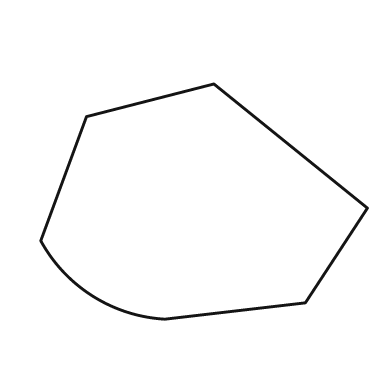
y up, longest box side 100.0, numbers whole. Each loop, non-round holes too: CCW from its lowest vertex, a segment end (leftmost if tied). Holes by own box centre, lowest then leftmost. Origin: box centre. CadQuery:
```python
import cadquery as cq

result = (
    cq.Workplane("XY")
    .moveTo(-12.0, -36.0)
    .lineTo(31.0, -31.0)
    .lineTo(50.0, -2.0)
    .lineTo(3.0, 36.0)
    .lineTo(-36.0, 26.0)
    .lineTo(-50.0, -12.0)
    .threePointArc((-34.0, -29.0), (-12.0, -36.0))
    .close()
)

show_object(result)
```